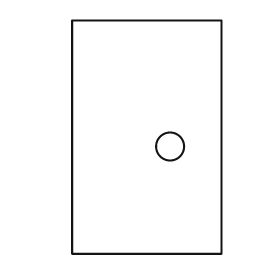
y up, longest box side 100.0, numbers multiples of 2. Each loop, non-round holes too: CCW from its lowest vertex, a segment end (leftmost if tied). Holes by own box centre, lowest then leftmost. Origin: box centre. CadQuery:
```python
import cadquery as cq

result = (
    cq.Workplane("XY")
    .moveTo(-32.0, -50.0)
    .lineTo(32.0, -50.0)
    .lineTo(32.0, 50.0)
    .lineTo(-32.0, 50.0)
    .close()
    .moveTo(10.0, -4.0)
    .circle(6.0)
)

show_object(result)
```